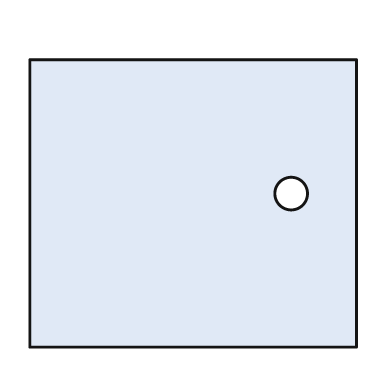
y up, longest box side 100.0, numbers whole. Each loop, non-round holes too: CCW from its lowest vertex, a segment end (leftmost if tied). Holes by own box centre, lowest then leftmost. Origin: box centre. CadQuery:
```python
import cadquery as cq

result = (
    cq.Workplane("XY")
    .moveTo(-50.0, -44.0)
    .lineTo(50.0, -44.0)
    .lineTo(50.0, 44.0)
    .lineTo(-50.0, 44.0)
    .close()
    .moveTo(30.0, 3.0)
    .circle(5.0)
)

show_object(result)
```